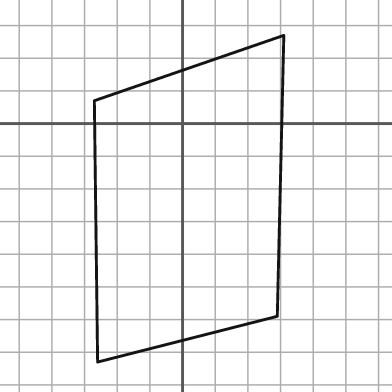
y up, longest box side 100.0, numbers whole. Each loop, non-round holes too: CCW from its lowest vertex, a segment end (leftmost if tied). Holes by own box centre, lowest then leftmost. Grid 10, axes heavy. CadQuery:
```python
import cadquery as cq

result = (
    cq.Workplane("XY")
    .moveTo(-26.0, -73.0)
    .lineTo(29.0, -59.0)
    .lineTo(31.0, 27.0)
    .lineTo(-27.0, 7.0)
    .close()
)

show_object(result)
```